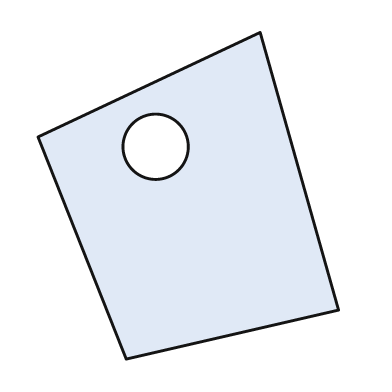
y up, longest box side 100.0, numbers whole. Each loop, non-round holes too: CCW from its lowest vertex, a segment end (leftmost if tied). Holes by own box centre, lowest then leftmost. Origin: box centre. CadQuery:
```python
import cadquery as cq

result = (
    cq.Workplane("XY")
    .moveTo(-19.0, -50.0)
    .lineTo(46.0, -35.0)
    .lineTo(22.0, 50.0)
    .lineTo(-46.0, 18.0)
    .close()
    .moveTo(-10.0, 15.0)
    .circle(10.0)
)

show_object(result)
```